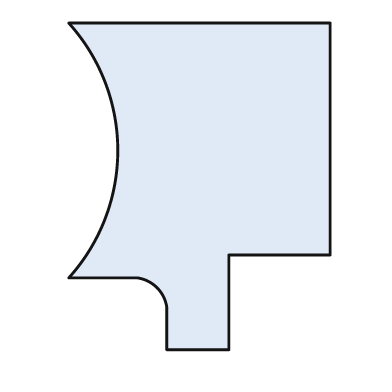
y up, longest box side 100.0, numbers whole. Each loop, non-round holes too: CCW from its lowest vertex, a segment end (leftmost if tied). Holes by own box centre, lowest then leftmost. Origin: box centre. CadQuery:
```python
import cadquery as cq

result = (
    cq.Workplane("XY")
    .moveTo(-10.0, -50.0)
    .lineTo(9.0, -50.0)
    .lineTo(9.0, -21.0)
    .lineTo(40.0, -21.0)
    .lineTo(40.0, 50.0)
    .lineTo(-40.0, 50.0)
    .threePointArc((-25.0, 11.0), (-40.0, -28.0))
    .lineTo(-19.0, -28.0)
    .threePointArc((-13.0, -31.0), (-10.0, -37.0))
    .close()
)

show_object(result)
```